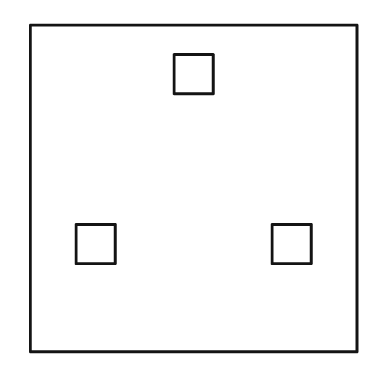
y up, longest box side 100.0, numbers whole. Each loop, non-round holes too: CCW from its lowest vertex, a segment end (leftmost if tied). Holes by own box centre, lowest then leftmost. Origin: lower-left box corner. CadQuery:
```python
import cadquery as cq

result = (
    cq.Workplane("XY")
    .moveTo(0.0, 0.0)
    .lineTo(100.0, 0.0)
    .lineTo(100.0, 100.0)
    .lineTo(0.0, 100.0)
    .close()
    .moveTo(14.0, 27.0)
    .lineTo(26.0, 27.0)
    .lineTo(26.0, 39.0)
    .lineTo(14.0, 39.0)
    .close()
    .moveTo(74.0, 27.0)
    .lineTo(86.0, 27.0)
    .lineTo(86.0, 39.0)
    .lineTo(74.0, 39.0)
    .close()
    .moveTo(44.0, 79.0)
    .lineTo(56.0, 79.0)
    .lineTo(56.0, 91.0)
    .lineTo(44.0, 91.0)
    .close()
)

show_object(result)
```